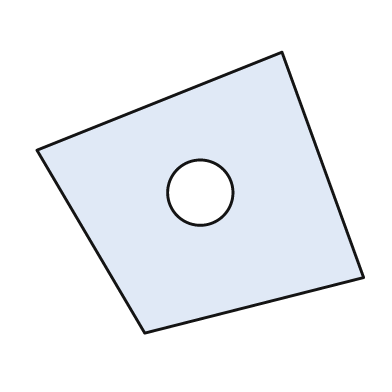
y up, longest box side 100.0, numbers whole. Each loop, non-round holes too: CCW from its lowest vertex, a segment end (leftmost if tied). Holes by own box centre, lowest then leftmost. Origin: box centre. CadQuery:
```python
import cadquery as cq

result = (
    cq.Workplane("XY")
    .moveTo(-17.0, -43.0)
    .lineTo(50.0, -26.0)
    .lineTo(25.0, 43.0)
    .lineTo(-50.0, 13.0)
    .close()
    .moveTo(0.0, 0.0)
    .circle(10.0)
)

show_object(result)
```